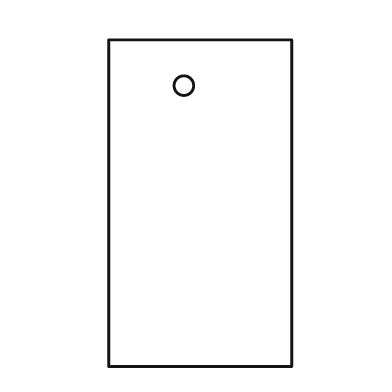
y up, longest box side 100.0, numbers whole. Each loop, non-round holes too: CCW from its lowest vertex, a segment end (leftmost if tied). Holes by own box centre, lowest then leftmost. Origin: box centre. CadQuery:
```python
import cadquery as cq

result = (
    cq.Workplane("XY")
    .moveTo(-28.0, -50.0)
    .lineTo(28.0, -50.0)
    .lineTo(28.0, 50.0)
    .lineTo(-28.0, 50.0)
    .close()
    .moveTo(-5.0, 36.0)
    .circle(3.0)
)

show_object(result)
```